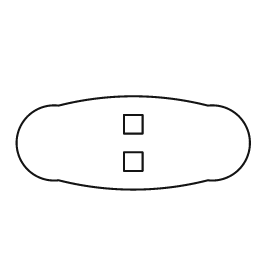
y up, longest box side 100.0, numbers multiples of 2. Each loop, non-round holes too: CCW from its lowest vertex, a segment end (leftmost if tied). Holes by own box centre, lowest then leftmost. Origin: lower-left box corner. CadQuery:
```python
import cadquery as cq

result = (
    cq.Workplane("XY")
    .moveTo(18.0, 4.0)
    .threePointArc((50.0, 0.0), (82.0, 4.0))
    .threePointArc((100.0, 20.0), (82.0, 36.0))
    .threePointArc((50.0, 40.0), (18.0, 36.0))
    .threePointArc((0.0, 20.0), (18.0, 4.0))
    .close()
    .moveTo(46.0, 8.0)
    .lineTo(54.0, 8.0)
    .lineTo(54.0, 16.0)
    .lineTo(46.0, 16.0)
    .close()
    .moveTo(46.0, 24.0)
    .lineTo(54.0, 24.0)
    .lineTo(54.0, 32.0)
    .lineTo(46.0, 32.0)
    .close()
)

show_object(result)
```